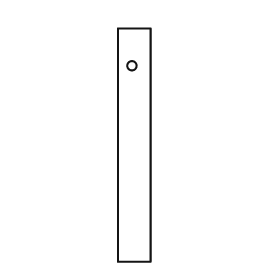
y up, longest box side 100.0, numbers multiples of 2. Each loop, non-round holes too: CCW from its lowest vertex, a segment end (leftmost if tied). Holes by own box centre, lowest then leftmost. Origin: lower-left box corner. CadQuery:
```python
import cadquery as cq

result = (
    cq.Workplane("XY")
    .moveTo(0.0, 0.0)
    .lineTo(14.0, 0.0)
    .lineTo(14.0, 100.0)
    .lineTo(0.0, 100.0)
    .close()
    .moveTo(6.0, 84.0)
    .circle(2.0)
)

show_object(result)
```